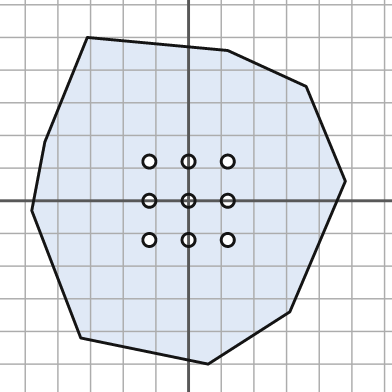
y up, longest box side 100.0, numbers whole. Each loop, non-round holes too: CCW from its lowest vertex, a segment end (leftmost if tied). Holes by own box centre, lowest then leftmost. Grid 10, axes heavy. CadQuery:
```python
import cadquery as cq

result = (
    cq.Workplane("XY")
    .moveTo(6.0, -50.0)
    .lineTo(31.0, -34.0)
    .lineTo(48.0, 6.0)
    .lineTo(36.0, 35.0)
    .lineTo(12.0, 46.0)
    .lineTo(-31.0, 50.0)
    .lineTo(-44.0, 18.0)
    .lineTo(-48.0, -3.0)
    .lineTo(-33.0, -42.0)
    .close()
    .moveTo(-12.0, -12.0)
    .circle(2.0)
    .moveTo(0.0, -12.0)
    .circle(2.0)
    .moveTo(12.0, -12.0)
    .circle(2.0)
    .moveTo(-12.0, 0.0)
    .circle(2.0)
    .moveTo(0.0, 0.0)
    .circle(2.0)
    .moveTo(12.0, 0.0)
    .circle(2.0)
    .moveTo(-12.0, 12.0)
    .circle(2.0)
    .moveTo(0.0, 12.0)
    .circle(2.0)
    .moveTo(12.0, 12.0)
    .circle(2.0)
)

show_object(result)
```